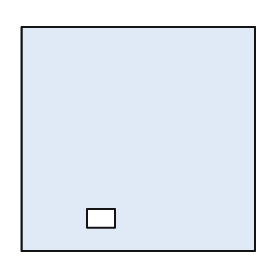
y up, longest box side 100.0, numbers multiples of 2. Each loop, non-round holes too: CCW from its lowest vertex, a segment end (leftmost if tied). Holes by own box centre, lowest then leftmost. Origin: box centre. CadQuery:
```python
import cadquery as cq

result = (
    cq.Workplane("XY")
    .moveTo(-50.0, -48.0)
    .lineTo(50.0, -48.0)
    .lineTo(50.0, 48.0)
    .lineTo(-50.0, 48.0)
    .close()
    .moveTo(-22.0, -38.0)
    .lineTo(-10.0, -38.0)
    .lineTo(-10.0, -30.0)
    .lineTo(-22.0, -30.0)
    .close()
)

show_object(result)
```